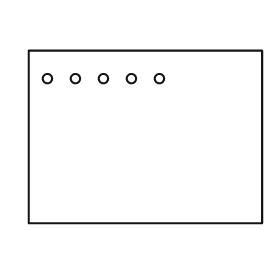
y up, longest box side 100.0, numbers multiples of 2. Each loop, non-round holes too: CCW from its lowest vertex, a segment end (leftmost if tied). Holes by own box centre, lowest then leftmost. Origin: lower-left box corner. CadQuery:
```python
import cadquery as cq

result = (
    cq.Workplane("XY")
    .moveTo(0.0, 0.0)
    .lineTo(100.0, 0.0)
    .lineTo(100.0, 74.0)
    .lineTo(0.0, 74.0)
    .close()
    .moveTo(8.0, 62.0)
    .circle(2.0)
    .moveTo(20.0, 62.0)
    .circle(2.0)
    .moveTo(32.0, 62.0)
    .circle(2.0)
    .moveTo(44.0, 62.0)
    .circle(2.0)
    .moveTo(56.0, 62.0)
    .circle(2.0)
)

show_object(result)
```